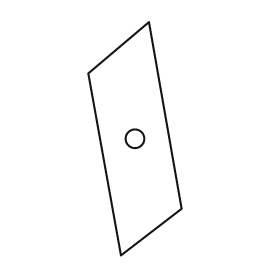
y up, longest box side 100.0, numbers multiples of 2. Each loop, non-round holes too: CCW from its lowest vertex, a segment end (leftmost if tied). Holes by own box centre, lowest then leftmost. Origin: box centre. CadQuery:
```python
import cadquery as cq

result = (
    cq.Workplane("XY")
    .moveTo(-6.0, -50.0)
    .lineTo(20.0, -30.0)
    .lineTo(6.0, 50.0)
    .lineTo(-20.0, 28.0)
    .close()
    .moveTo(0.0, 0.0)
    .circle(4.0)
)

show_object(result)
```